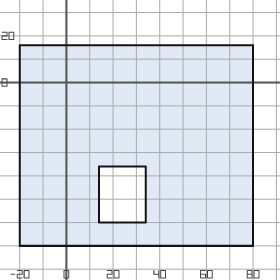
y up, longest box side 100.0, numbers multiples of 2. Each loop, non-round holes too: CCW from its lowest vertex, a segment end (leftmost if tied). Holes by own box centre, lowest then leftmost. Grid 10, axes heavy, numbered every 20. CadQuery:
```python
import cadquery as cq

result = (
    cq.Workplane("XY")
    .moveTo(-20.0, -70.0)
    .lineTo(80.0, -70.0)
    .lineTo(80.0, 16.0)
    .lineTo(-20.0, 16.0)
    .close()
    .moveTo(14.0, -60.0)
    .lineTo(34.0, -60.0)
    .lineTo(34.0, -36.0)
    .lineTo(14.0, -36.0)
    .close()
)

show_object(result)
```